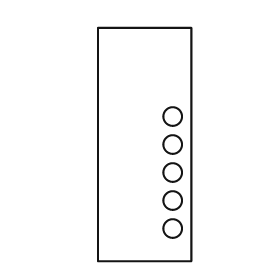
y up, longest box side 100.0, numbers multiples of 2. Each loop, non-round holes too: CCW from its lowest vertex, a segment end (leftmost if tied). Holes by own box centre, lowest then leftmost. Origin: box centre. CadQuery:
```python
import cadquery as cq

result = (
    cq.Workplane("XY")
    .moveTo(-20.0, -50.0)
    .lineTo(20.0, -50.0)
    .lineTo(20.0, 50.0)
    .lineTo(-20.0, 50.0)
    .close()
    .moveTo(12.0, -36.0)
    .circle(4.0)
    .moveTo(12.0, -24.0)
    .circle(4.0)
    .moveTo(12.0, -12.0)
    .circle(4.0)
    .moveTo(12.0, 0.0)
    .circle(4.0)
    .moveTo(12.0, 12.0)
    .circle(4.0)
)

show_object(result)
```